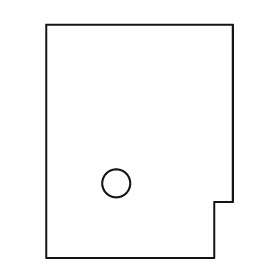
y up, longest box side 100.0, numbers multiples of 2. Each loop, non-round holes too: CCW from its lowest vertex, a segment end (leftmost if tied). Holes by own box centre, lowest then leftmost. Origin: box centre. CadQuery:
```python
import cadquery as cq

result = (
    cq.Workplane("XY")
    .moveTo(-40.0, -50.0)
    .lineTo(32.0, -50.0)
    .lineTo(32.0, -26.0)
    .lineTo(40.0, -26.0)
    .lineTo(40.0, 50.0)
    .lineTo(-40.0, 50.0)
    .close()
    .moveTo(-10.0, -18.0)
    .circle(6.0)
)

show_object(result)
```